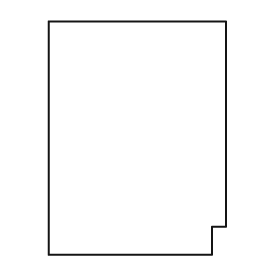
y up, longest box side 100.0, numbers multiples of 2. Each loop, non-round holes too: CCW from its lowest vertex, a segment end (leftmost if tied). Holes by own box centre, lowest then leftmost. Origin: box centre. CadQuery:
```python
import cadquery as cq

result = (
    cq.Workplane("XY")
    .moveTo(-38.0, -50.0)
    .lineTo(32.0, -50.0)
    .lineTo(32.0, -38.0)
    .lineTo(38.0, -38.0)
    .lineTo(38.0, 50.0)
    .lineTo(-38.0, 50.0)
    .close()
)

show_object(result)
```